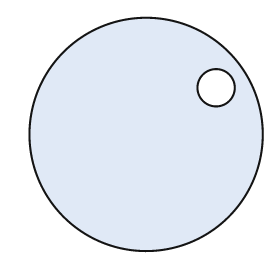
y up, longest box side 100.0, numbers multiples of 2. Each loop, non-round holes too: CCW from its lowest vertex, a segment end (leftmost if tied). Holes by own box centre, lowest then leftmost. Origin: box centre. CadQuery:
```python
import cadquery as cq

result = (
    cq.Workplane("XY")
    .moveTo(0.0, 0.0)
    .circle(50.0)
    .moveTo(30.0, 20.0)
    .circle(8.0)
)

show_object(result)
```